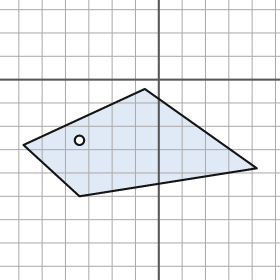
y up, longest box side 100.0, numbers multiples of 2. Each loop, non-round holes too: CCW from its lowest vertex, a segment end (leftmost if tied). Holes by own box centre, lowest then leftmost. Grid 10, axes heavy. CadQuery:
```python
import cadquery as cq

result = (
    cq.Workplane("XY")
    .moveTo(-34.0, -50.0)
    .lineTo(42.0, -38.0)
    .lineTo(-6.0, -4.0)
    .lineTo(-58.0, -28.0)
    .close()
    .moveTo(-34.0, -26.0)
    .circle(2.0)
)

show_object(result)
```